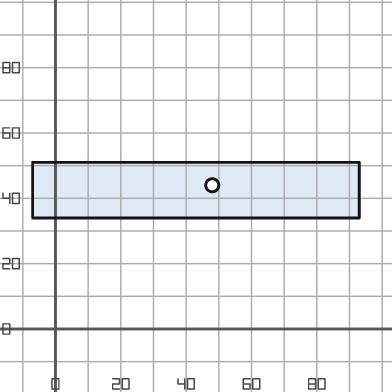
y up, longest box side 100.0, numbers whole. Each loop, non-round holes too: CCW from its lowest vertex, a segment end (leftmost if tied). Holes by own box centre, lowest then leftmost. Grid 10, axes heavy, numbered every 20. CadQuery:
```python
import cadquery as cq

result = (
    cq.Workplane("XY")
    .moveTo(-7.0, 34.0)
    .lineTo(93.0, 34.0)
    .lineTo(93.0, 51.0)
    .lineTo(-7.0, 51.0)
    .close()
    .moveTo(48.0, 44.0)
    .circle(2.0)
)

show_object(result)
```